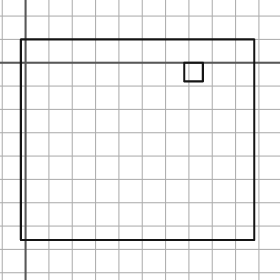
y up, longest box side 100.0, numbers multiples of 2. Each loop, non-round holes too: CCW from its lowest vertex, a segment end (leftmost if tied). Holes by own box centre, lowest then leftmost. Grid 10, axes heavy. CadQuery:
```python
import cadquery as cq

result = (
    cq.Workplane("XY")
    .moveTo(-2.0, -76.0)
    .lineTo(98.0, -76.0)
    .lineTo(98.0, 10.0)
    .lineTo(-2.0, 10.0)
    .close()
    .moveTo(68.0, -8.0)
    .lineTo(76.0, -8.0)
    .lineTo(76.0, 0.0)
    .lineTo(68.0, 0.0)
    .close()
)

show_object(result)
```